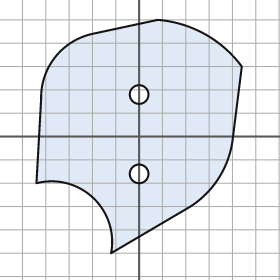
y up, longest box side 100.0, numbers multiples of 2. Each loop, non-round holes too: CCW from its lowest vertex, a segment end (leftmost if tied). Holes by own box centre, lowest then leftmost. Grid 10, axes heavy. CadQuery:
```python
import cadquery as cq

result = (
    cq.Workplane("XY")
    .moveTo(-12.0, -50.0)
    .lineTo(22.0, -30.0)
    .threePointArc((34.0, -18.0), (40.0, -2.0))
    .lineTo(44.0, 30.0)
    .threePointArc((28.0, 44.0), (8.0, 50.0))
    .lineTo(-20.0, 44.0)
    .threePointArc((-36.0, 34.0), (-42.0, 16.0))
    .lineTo(-44.0, -20.0)
    .threePointArc((-20.0, -26.0), (-12.0, -50.0))
    .close()
    .moveTo(0.0, -16.0)
    .circle(4.0)
    .moveTo(0.0, 18.0)
    .circle(4.0)
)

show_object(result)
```